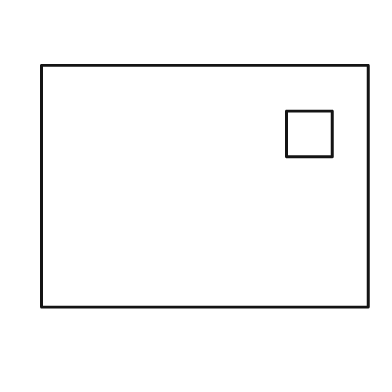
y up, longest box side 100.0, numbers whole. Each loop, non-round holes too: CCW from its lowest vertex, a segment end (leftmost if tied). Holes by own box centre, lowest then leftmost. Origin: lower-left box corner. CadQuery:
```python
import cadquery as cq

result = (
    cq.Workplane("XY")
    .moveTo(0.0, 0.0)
    .lineTo(100.0, 0.0)
    .lineTo(100.0, 74.0)
    .lineTo(0.0, 74.0)
    .close()
    .moveTo(75.0, 46.0)
    .lineTo(89.0, 46.0)
    .lineTo(89.0, 60.0)
    .lineTo(75.0, 60.0)
    .close()
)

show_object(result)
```